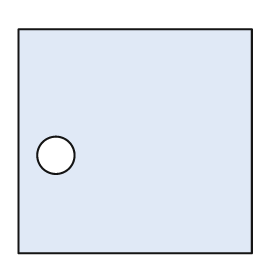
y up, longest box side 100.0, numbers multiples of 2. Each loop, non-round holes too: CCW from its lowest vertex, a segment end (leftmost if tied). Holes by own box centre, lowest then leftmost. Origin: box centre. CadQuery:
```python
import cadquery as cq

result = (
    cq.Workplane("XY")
    .moveTo(-50.0, -48.0)
    .lineTo(50.0, -48.0)
    .lineTo(50.0, 48.0)
    .lineTo(-50.0, 48.0)
    .close()
    .moveTo(-34.0, -6.0)
    .circle(8.0)
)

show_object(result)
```